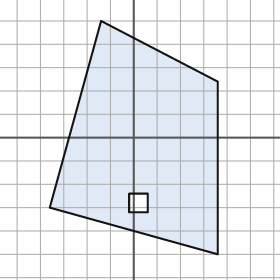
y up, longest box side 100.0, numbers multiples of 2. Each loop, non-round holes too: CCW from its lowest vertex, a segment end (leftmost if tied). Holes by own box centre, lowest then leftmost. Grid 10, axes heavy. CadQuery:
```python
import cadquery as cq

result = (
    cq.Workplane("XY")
    .moveTo(36.0, -50.0)
    .lineTo(36.0, 24.0)
    .lineTo(-14.0, 50.0)
    .lineTo(-36.0, -30.0)
    .close()
    .moveTo(-2.0, -32.0)
    .lineTo(6.0, -32.0)
    .lineTo(6.0, -24.0)
    .lineTo(-2.0, -24.0)
    .close()
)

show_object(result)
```